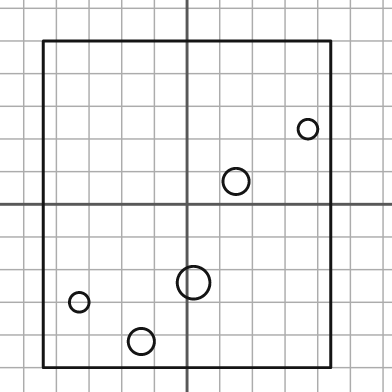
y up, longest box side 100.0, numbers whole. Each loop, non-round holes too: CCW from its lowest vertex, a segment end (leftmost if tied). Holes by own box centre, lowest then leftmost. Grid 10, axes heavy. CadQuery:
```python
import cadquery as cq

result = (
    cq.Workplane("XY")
    .moveTo(-44.0, -50.0)
    .lineTo(44.0, -50.0)
    .lineTo(44.0, 50.0)
    .lineTo(-44.0, 50.0)
    .close()
    .moveTo(-14.0, -42.0)
    .circle(4.0)
    .moveTo(-33.0, -30.0)
    .circle(3.0)
    .moveTo(2.0, -24.0)
    .circle(5.0)
    .moveTo(15.0, 7.0)
    .circle(4.0)
    .moveTo(37.0, 23.0)
    .circle(3.0)
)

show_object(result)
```